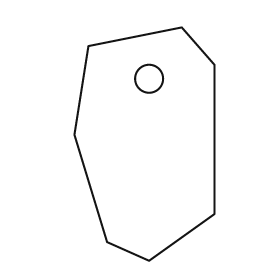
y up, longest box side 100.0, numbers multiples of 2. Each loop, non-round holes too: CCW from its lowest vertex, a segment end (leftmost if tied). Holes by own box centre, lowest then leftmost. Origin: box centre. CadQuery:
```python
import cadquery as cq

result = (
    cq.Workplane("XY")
    .moveTo(2.0, -50.0)
    .lineTo(30.0, -30.0)
    .lineTo(30.0, 34.0)
    .lineTo(16.0, 50.0)
    .lineTo(-24.0, 42.0)
    .lineTo(-30.0, 4.0)
    .lineTo(-16.0, -42.0)
    .close()
    .moveTo(2.0, 28.0)
    .circle(6.0)
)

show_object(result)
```